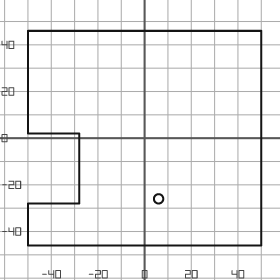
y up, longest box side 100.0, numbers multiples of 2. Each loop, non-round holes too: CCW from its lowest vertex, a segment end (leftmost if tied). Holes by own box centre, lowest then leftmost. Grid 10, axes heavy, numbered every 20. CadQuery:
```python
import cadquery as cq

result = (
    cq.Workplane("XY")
    .moveTo(-50.0, -46.0)
    .lineTo(50.0, -46.0)
    .lineTo(50.0, 46.0)
    .lineTo(-50.0, 46.0)
    .lineTo(-50.0, 2.0)
    .lineTo(-28.0, 2.0)
    .lineTo(-28.0, -28.0)
    .lineTo(-50.0, -28.0)
    .close()
    .moveTo(6.0, -26.0)
    .circle(2.0)
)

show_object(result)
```